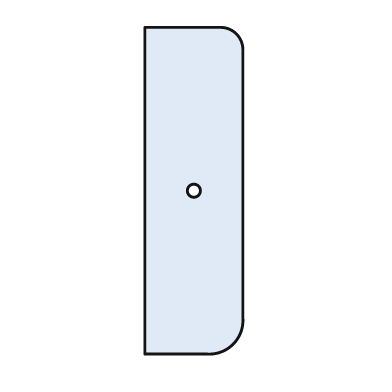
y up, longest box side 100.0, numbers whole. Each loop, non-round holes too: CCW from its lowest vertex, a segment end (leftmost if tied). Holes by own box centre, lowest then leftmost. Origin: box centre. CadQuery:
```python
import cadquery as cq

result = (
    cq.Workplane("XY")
    .moveTo(-15.0, -50.0)
    .lineTo(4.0, -50.0)
    .threePointArc((12.0, -47.0), (15.0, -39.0))
    .lineTo(15.0, 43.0)
    .threePointArc((13.0, 48.0), (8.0, 50.0))
    .lineTo(-15.0, 50.0)
    .close()
    .moveTo(0.0, 0.0)
    .circle(2.0)
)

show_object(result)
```